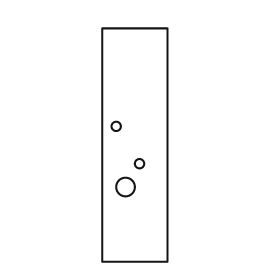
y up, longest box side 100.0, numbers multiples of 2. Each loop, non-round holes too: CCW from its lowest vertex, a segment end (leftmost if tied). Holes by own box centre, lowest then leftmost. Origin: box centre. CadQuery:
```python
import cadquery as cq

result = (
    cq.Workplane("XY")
    .moveTo(-14.0, -50.0)
    .lineTo(14.0, -50.0)
    .lineTo(14.0, 50.0)
    .lineTo(-14.0, 50.0)
    .close()
    .moveTo(-4.0, -18.0)
    .circle(4.0)
    .moveTo(2.0, -8.0)
    .circle(2.0)
    .moveTo(-8.0, 8.0)
    .circle(2.0)
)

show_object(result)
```